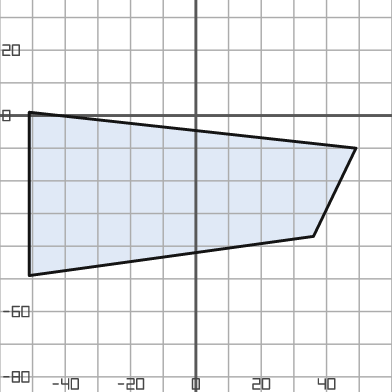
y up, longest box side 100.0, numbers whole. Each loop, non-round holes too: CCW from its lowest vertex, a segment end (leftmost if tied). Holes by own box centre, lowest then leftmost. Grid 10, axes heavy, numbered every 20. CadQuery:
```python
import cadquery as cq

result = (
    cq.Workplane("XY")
    .moveTo(-51.0, -49.0)
    .lineTo(36.0, -37.0)
    .lineTo(49.0, -10.0)
    .lineTo(-51.0, 1.0)
    .close()
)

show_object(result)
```